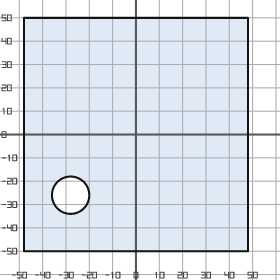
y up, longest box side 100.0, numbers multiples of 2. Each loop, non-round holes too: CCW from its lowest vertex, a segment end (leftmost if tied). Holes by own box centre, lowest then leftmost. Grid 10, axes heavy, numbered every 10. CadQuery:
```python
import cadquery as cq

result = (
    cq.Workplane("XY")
    .moveTo(-48.0, -50.0)
    .lineTo(48.0, -50.0)
    .lineTo(48.0, 50.0)
    .lineTo(-48.0, 50.0)
    .close()
    .moveTo(-28.0, -26.0)
    .circle(8.0)
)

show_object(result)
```